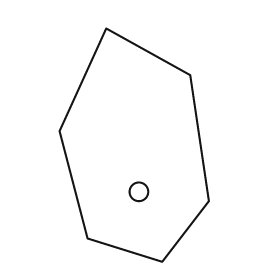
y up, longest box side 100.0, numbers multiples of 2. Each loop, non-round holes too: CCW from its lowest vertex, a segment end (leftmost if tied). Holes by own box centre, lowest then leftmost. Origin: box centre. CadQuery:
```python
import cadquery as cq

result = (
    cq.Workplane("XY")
    .moveTo(12.0, -50.0)
    .lineTo(32.0, -24.0)
    .lineTo(24.0, 30.0)
    .lineTo(-12.0, 50.0)
    .lineTo(-32.0, 6.0)
    .lineTo(-20.0, -40.0)
    .close()
    .moveTo(2.0, -20.0)
    .circle(4.0)
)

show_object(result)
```